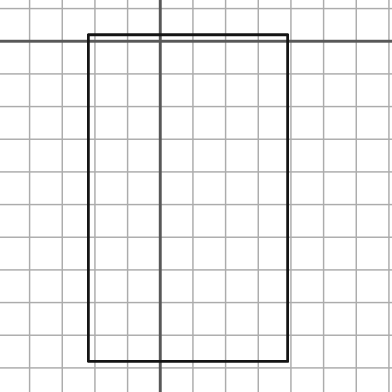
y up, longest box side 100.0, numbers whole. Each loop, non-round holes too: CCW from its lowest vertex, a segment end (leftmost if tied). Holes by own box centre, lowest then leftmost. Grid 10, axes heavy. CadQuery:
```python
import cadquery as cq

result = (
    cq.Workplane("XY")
    .moveTo(-22.0, -98.0)
    .lineTo(39.0, -98.0)
    .lineTo(39.0, 2.0)
    .lineTo(-22.0, 2.0)
    .close()
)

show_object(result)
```